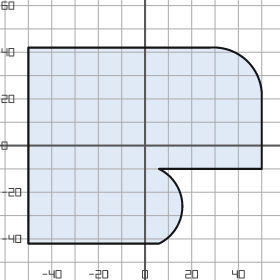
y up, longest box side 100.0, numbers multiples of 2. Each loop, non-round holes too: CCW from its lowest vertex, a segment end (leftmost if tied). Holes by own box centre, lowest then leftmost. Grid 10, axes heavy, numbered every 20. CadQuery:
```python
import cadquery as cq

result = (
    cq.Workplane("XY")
    .moveTo(-50.0, -42.0)
    .lineTo(6.0, -42.0)
    .threePointArc((16.0, -26.0), (6.0, -10.0))
    .lineTo(50.0, -10.0)
    .lineTo(50.0, 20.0)
    .threePointArc((44.0, 36.0), (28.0, 42.0))
    .lineTo(-50.0, 42.0)
    .close()
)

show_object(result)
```